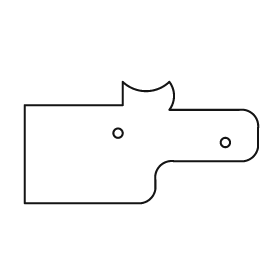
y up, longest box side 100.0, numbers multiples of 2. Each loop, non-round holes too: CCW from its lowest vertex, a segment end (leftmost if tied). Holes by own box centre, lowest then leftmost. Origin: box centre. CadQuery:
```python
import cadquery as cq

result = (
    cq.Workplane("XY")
    .moveTo(-50.0, -26.0)
    .lineTo(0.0, -26.0)
    .threePointArc((4.0, -24.0), (6.0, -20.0))
    .lineTo(6.0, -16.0)
    .threePointArc((8.0, -10.0), (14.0, -8.0))
    .lineTo(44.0, -8.0)
    .threePointArc((48.0, -6.0), (50.0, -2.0))
    .lineTo(50.0, 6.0)
    .threePointArc((48.0, 12.0), (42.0, 14.0))
    .lineTo(12.0, 14.0)
    .threePointArc((14.0, 20.0), (12.0, 26.0))
    .threePointArc((2.0, 22.0), (-8.0, 26.0))
    .lineTo(-8.0, 16.0)
    .lineTo(-50.0, 16.0)
    .close()
    .moveTo(36.0, 0.0)
    .circle(2.0)
    .moveTo(-10.0, 4.0)
    .circle(2.0)
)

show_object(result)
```